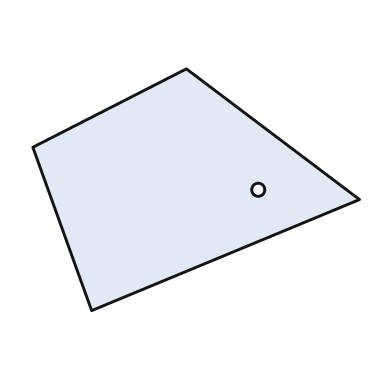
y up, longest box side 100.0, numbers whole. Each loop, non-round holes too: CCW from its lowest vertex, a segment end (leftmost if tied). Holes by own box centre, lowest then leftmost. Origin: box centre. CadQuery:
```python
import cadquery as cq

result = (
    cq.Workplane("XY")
    .moveTo(-32.0, -37.0)
    .lineTo(50.0, -3.0)
    .lineTo(-3.0, 37.0)
    .lineTo(-50.0, 13.0)
    .close()
    .moveTo(19.0, 0.0)
    .circle(2.0)
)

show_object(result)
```